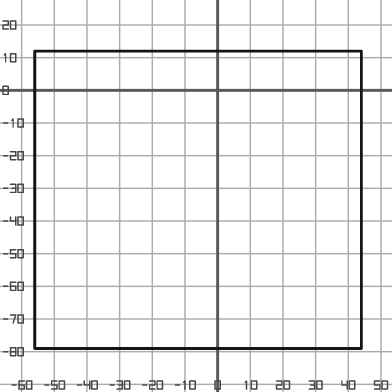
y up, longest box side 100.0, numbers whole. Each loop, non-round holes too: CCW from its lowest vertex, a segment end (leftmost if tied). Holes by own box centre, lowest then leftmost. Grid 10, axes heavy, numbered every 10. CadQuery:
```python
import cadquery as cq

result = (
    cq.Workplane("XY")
    .moveTo(-56.0, -79.0)
    .lineTo(44.0, -79.0)
    .lineTo(44.0, 12.0)
    .lineTo(-56.0, 12.0)
    .close()
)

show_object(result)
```